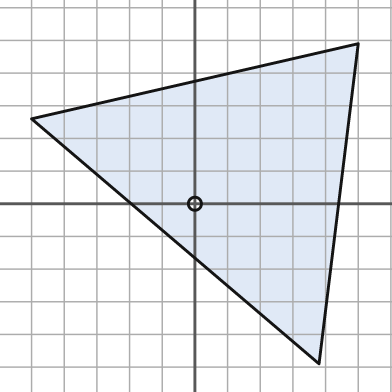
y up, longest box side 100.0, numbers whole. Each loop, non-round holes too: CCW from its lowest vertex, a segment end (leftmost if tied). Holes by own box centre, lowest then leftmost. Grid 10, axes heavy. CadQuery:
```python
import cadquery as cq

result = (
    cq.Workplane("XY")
    .moveTo(38.0, -49.0)
    .lineTo(50.0, 49.0)
    .lineTo(-50.0, 26.0)
    .close()
    .moveTo(0.0, 0.0)
    .circle(2.0)
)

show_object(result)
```